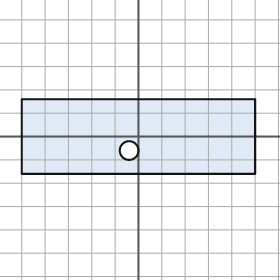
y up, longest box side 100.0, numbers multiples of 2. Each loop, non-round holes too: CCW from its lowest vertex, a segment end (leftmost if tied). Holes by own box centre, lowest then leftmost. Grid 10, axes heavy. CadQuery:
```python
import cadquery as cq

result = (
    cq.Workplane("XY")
    .moveTo(-50.0, -16.0)
    .lineTo(50.0, -16.0)
    .lineTo(50.0, 16.0)
    .lineTo(-50.0, 16.0)
    .close()
    .moveTo(-4.0, -6.0)
    .circle(4.0)
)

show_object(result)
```